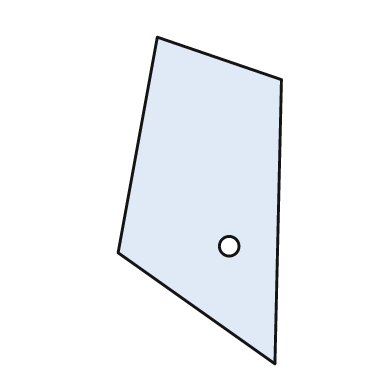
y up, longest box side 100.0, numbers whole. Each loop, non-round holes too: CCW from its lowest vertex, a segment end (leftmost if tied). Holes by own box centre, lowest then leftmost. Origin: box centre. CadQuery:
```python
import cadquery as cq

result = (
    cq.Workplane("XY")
    .moveTo(23.0, -50.0)
    .lineTo(25.0, 37.0)
    .lineTo(-13.0, 50.0)
    .lineTo(-25.0, -16.0)
    .close()
    .moveTo(9.0, -14.0)
    .circle(3.0)
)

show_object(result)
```